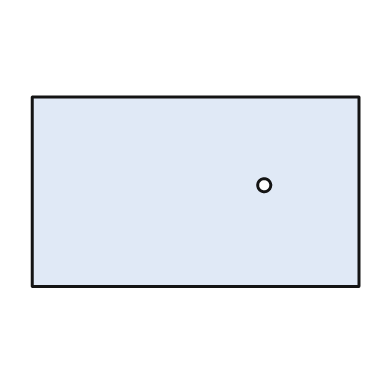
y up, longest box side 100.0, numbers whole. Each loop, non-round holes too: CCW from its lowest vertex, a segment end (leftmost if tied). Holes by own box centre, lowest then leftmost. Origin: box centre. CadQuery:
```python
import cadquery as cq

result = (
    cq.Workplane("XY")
    .moveTo(-50.0, -29.0)
    .lineTo(50.0, -29.0)
    .lineTo(50.0, 29.0)
    .lineTo(-50.0, 29.0)
    .close()
    .moveTo(21.0, 2.0)
    .circle(2.0)
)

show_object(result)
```